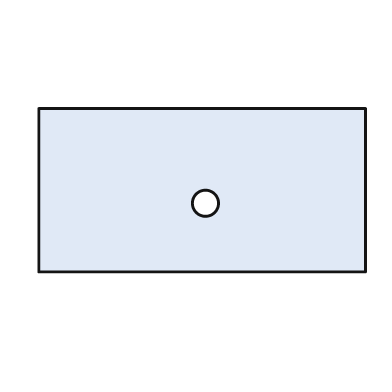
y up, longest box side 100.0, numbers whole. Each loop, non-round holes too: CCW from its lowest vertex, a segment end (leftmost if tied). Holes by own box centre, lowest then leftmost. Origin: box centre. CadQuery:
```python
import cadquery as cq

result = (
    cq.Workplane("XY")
    .moveTo(-50.0, -25.0)
    .lineTo(50.0, -25.0)
    .lineTo(50.0, 25.0)
    .lineTo(-50.0, 25.0)
    .close()
    .moveTo(1.0, -4.0)
    .circle(4.0)
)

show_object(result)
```